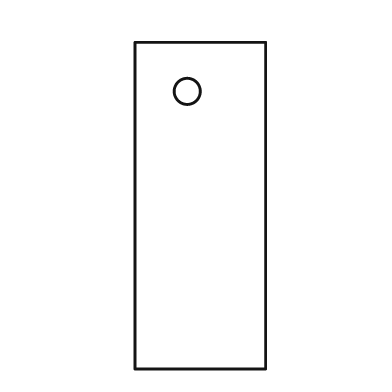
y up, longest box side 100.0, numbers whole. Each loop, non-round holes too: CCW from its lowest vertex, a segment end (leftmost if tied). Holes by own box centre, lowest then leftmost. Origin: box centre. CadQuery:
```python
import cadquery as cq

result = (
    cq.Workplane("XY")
    .moveTo(-20.0, -50.0)
    .lineTo(20.0, -50.0)
    .lineTo(20.0, 50.0)
    .lineTo(-20.0, 50.0)
    .close()
    .moveTo(-4.0, 35.0)
    .circle(4.0)
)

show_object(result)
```